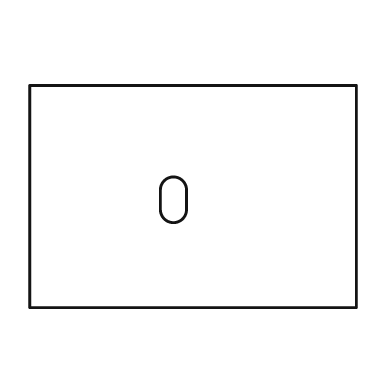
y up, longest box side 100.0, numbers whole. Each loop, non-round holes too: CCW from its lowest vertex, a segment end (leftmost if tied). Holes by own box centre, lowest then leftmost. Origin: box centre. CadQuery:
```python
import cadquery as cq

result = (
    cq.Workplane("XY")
    .moveTo(-50.0, -34.0)
    .lineTo(50.0, -34.0)
    .lineTo(50.0, 34.0)
    .lineTo(-50.0, 34.0)
    .close()
    .moveTo(-10.0, -4.0)
    .threePointArc((-6.0, -8.0), (-2.0, -4.0))
    .lineTo(-2.0, 2.0)
    .threePointArc((-6.0, 6.0), (-10.0, 2.0))
    .close()
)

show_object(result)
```